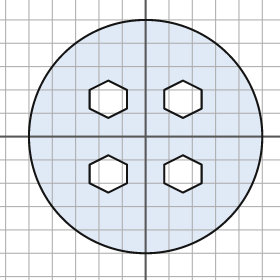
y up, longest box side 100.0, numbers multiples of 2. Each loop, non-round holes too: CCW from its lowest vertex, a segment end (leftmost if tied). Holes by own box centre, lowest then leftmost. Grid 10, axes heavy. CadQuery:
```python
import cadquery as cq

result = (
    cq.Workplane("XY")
    .moveTo(0.0, 0.0)
    .circle(50.0)
    .moveTo(-16.0, -24.0)
    .lineTo(-8.0, -20.0)
    .lineTo(-8.0, -12.0)
    .lineTo(-16.0, -8.0)
    .lineTo(-24.0, -12.0)
    .lineTo(-24.0, -20.0)
    .close()
    .moveTo(16.0, -24.0)
    .lineTo(24.0, -20.0)
    .lineTo(24.0, -12.0)
    .lineTo(16.0, -8.0)
    .lineTo(8.0, -12.0)
    .lineTo(8.0, -20.0)
    .close()
    .moveTo(-16.0, 8.0)
    .lineTo(-8.0, 12.0)
    .lineTo(-8.0, 20.0)
    .lineTo(-16.0, 24.0)
    .lineTo(-24.0, 20.0)
    .lineTo(-24.0, 12.0)
    .close()
    .moveTo(16.0, 8.0)
    .lineTo(24.0, 12.0)
    .lineTo(24.0, 20.0)
    .lineTo(16.0, 24.0)
    .lineTo(8.0, 20.0)
    .lineTo(8.0, 12.0)
    .close()
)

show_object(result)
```